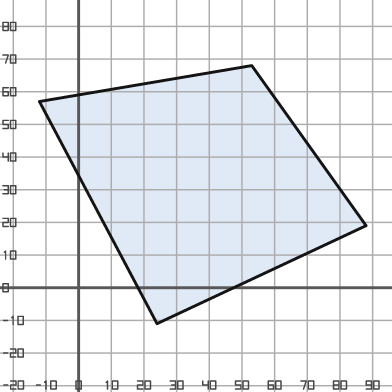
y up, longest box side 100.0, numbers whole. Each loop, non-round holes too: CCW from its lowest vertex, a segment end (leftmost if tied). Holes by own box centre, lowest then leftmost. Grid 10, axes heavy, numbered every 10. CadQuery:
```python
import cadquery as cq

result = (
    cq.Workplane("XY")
    .moveTo(24.0, -11.0)
    .lineTo(88.0, 19.0)
    .lineTo(53.0, 68.0)
    .lineTo(-12.0, 57.0)
    .close()
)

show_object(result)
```